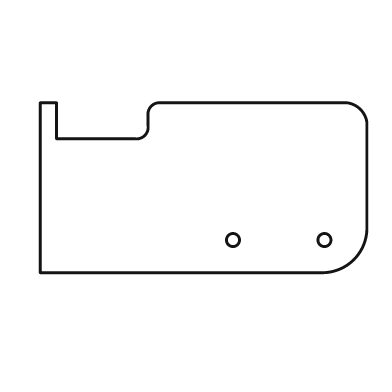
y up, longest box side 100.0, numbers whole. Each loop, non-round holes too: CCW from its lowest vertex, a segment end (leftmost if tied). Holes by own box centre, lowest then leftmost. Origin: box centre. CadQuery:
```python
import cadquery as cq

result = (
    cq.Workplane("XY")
    .moveTo(-50.0, -26.0)
    .lineTo(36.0, -26.0)
    .threePointArc((46.0, -22.0), (50.0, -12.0))
    .lineTo(50.0, 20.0)
    .threePointArc((48.0, 24.0), (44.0, 26.0))
    .lineTo(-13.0, 26.0)
    .threePointArc((-16.0, 25.0), (-17.0, 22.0))
    .lineTo(-17.0, 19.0)
    .threePointArc((-18.0, 16.0), (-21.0, 15.0))
    .lineTo(-45.0, 15.0)
    .lineTo(-45.0, 26.0)
    .lineTo(-50.0, 26.0)
    .close()
    .moveTo(9.0, -16.0)
    .circle(2.0)
    .moveTo(37.0, -16.0)
    .circle(2.0)
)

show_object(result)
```